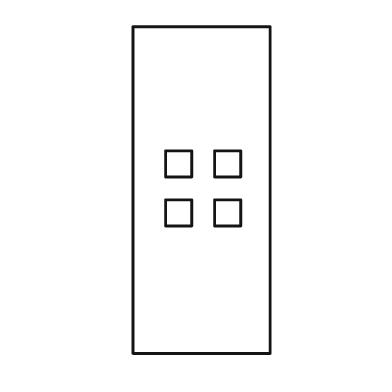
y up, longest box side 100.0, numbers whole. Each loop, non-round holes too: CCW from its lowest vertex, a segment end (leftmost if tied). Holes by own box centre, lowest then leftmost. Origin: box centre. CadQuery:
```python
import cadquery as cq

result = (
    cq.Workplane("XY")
    .moveTo(-21.0, -50.0)
    .lineTo(21.0, -50.0)
    .lineTo(21.0, 50.0)
    .lineTo(-21.0, 50.0)
    .close()
    .moveTo(-11.0, -11.0)
    .lineTo(-3.0, -11.0)
    .lineTo(-3.0, -3.0)
    .lineTo(-11.0, -3.0)
    .close()
    .moveTo(4.0, -11.0)
    .lineTo(12.0, -11.0)
    .lineTo(12.0, -3.0)
    .lineTo(4.0, -3.0)
    .close()
    .moveTo(-11.0, 4.0)
    .lineTo(-3.0, 4.0)
    .lineTo(-3.0, 12.0)
    .lineTo(-11.0, 12.0)
    .close()
    .moveTo(4.0, 4.0)
    .lineTo(12.0, 4.0)
    .lineTo(12.0, 12.0)
    .lineTo(4.0, 12.0)
    .close()
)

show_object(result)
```